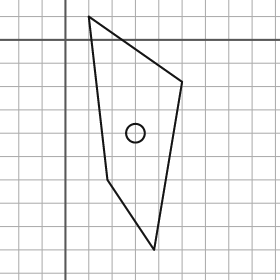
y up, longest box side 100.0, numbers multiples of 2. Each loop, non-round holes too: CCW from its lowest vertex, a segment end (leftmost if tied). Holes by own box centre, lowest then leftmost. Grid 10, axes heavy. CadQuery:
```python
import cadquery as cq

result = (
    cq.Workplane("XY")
    .moveTo(38.0, -90.0)
    .lineTo(50.0, -18.0)
    .lineTo(10.0, 10.0)
    .lineTo(18.0, -60.0)
    .close()
    .moveTo(30.0, -40.0)
    .circle(4.0)
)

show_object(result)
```